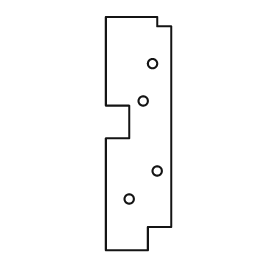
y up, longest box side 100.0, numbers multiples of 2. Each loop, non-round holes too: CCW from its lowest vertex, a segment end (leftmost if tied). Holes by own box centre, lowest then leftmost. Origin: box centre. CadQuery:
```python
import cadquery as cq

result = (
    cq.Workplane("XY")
    .moveTo(-14.0, -50.0)
    .lineTo(4.0, -50.0)
    .lineTo(4.0, -40.0)
    .lineTo(14.0, -40.0)
    .lineTo(14.0, 46.0)
    .lineTo(8.0, 46.0)
    .lineTo(8.0, 50.0)
    .lineTo(-14.0, 50.0)
    .lineTo(-14.0, 12.0)
    .lineTo(-4.0, 12.0)
    .lineTo(-4.0, -2.0)
    .lineTo(-14.0, -2.0)
    .close()
    .moveTo(-4.0, -28.0)
    .circle(2.0)
    .moveTo(8.0, -16.0)
    .circle(2.0)
    .moveTo(2.0, 14.0)
    .circle(2.0)
    .moveTo(6.0, 30.0)
    .circle(2.0)
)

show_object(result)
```